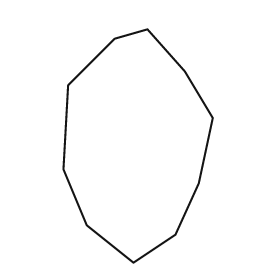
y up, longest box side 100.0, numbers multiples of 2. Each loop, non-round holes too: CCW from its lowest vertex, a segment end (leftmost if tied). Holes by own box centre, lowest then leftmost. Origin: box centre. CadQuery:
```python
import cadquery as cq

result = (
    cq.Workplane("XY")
    .moveTo(-2.0, -50.0)
    .lineTo(16.0, -38.0)
    .lineTo(26.0, -16.0)
    .lineTo(32.0, 12.0)
    .lineTo(20.0, 32.0)
    .lineTo(4.0, 50.0)
    .lineTo(-10.0, 46.0)
    .lineTo(-30.0, 26.0)
    .lineTo(-32.0, -10.0)
    .lineTo(-22.0, -34.0)
    .close()
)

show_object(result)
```